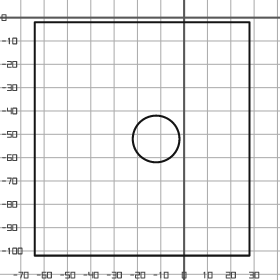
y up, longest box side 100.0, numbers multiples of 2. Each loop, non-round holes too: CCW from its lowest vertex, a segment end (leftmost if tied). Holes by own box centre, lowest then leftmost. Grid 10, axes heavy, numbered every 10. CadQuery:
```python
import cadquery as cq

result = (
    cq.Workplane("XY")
    .moveTo(-64.0, -102.0)
    .lineTo(28.0, -102.0)
    .lineTo(28.0, -2.0)
    .lineTo(-64.0, -2.0)
    .close()
    .moveTo(-12.0, -52.0)
    .circle(10.0)
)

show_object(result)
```